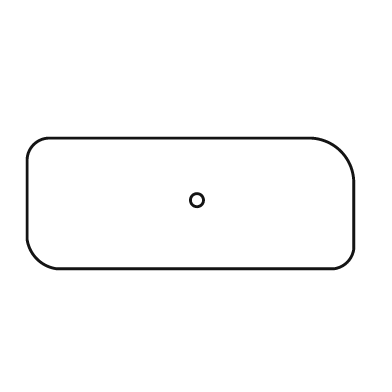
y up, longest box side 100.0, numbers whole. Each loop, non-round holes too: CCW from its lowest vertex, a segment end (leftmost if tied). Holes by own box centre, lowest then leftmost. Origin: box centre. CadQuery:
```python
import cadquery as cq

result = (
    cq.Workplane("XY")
    .moveTo(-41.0, -20.0)
    .lineTo(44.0, -20.0)
    .threePointArc((48.0, -18.0), (50.0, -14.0))
    .lineTo(50.0, 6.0)
    .threePointArc((46.0, 16.0), (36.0, 20.0))
    .lineTo(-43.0, 20.0)
    .threePointArc((-48.0, 18.0), (-50.0, 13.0))
    .lineTo(-50.0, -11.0)
    .threePointArc((-47.0, -17.0), (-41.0, -20.0))
    .close()
    .moveTo(2.0, 1.0)
    .circle(2.0)
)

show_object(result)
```